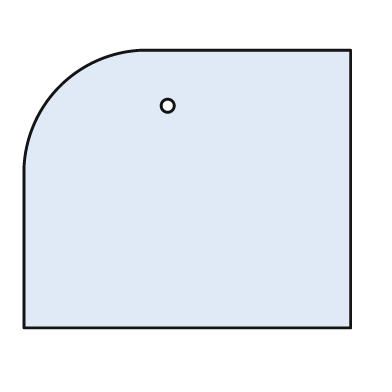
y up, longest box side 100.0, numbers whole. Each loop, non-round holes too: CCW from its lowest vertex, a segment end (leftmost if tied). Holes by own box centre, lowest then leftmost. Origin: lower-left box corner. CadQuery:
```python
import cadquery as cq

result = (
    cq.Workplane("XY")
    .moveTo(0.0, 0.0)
    .lineTo(100.0, 0.0)
    .lineTo(100.0, 85.0)
    .lineTo(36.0, 85.0)
    .threePointArc((11.0, 74.0), (0.0, 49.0))
    .close()
    .moveTo(44.0, 68.0)
    .circle(2.0)
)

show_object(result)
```